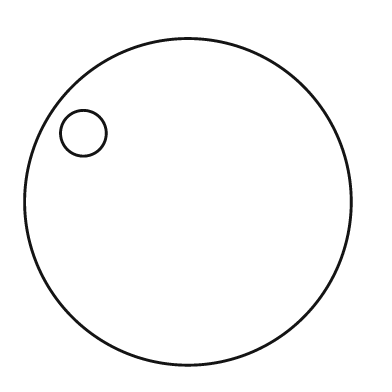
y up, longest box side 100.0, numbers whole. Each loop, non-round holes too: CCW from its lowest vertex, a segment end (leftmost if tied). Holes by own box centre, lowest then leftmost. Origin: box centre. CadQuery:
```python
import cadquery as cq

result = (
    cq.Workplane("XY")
    .moveTo(0.0, 0.0)
    .circle(50.0)
    .moveTo(-32.0, 21.0)
    .circle(7.0)
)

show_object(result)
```